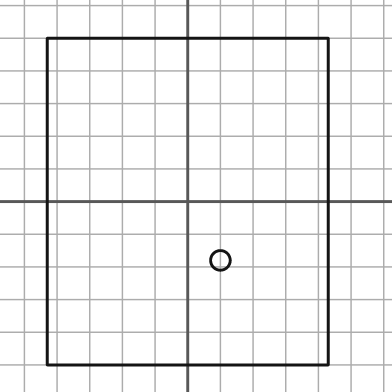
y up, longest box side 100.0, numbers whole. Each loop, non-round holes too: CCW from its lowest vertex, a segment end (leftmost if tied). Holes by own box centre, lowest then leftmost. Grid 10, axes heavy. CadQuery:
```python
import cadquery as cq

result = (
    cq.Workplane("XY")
    .moveTo(-43.0, -50.0)
    .lineTo(43.0, -50.0)
    .lineTo(43.0, 50.0)
    .lineTo(-43.0, 50.0)
    .close()
    .moveTo(10.0, -18.0)
    .circle(3.0)
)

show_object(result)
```